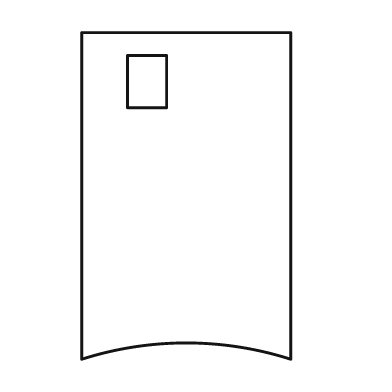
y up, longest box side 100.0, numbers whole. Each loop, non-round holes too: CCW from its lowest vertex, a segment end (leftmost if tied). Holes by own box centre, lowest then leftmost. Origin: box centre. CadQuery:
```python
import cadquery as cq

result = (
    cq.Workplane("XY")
    .moveTo(-32.0, -50.0)
    .threePointArc((0.0, -45.0), (32.0, -50.0))
    .lineTo(32.0, 50.0)
    .lineTo(-32.0, 50.0)
    .close()
    .moveTo(-18.0, 27.0)
    .lineTo(-6.0, 27.0)
    .lineTo(-6.0, 43.0)
    .lineTo(-18.0, 43.0)
    .close()
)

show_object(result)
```